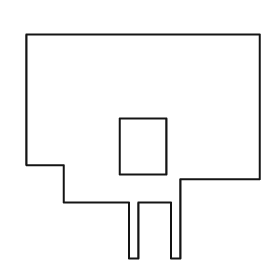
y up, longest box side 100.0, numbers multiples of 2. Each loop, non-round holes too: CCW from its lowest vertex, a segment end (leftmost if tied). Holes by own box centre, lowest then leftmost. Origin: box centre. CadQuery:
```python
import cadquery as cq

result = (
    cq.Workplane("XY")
    .moveTo(-6.0, -48.0)
    .lineTo(-2.0, -48.0)
    .lineTo(-2.0, -24.0)
    .lineTo(12.0, -24.0)
    .lineTo(12.0, -48.0)
    .lineTo(16.0, -48.0)
    .lineTo(16.0, -14.0)
    .lineTo(50.0, -14.0)
    .lineTo(50.0, 48.0)
    .lineTo(-50.0, 48.0)
    .lineTo(-50.0, -8.0)
    .lineTo(-34.0, -8.0)
    .lineTo(-34.0, -24.0)
    .lineTo(-6.0, -24.0)
    .close()
    .moveTo(-10.0, -12.0)
    .lineTo(10.0, -12.0)
    .lineTo(10.0, 12.0)
    .lineTo(-10.0, 12.0)
    .close()
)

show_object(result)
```